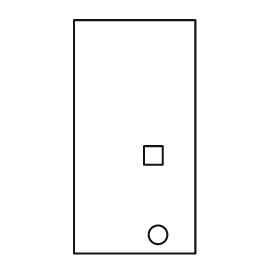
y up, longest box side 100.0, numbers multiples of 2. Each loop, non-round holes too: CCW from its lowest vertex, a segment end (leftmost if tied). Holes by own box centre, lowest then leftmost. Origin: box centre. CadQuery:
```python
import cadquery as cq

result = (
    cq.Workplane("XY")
    .moveTo(-26.0, -50.0)
    .lineTo(26.0, -50.0)
    .lineTo(26.0, 50.0)
    .lineTo(-26.0, 50.0)
    .close()
    .moveTo(10.0, -42.0)
    .circle(4.0)
    .moveTo(4.0, -12.0)
    .lineTo(12.0, -12.0)
    .lineTo(12.0, -4.0)
    .lineTo(4.0, -4.0)
    .close()
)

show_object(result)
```